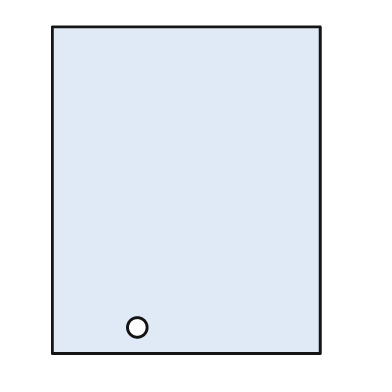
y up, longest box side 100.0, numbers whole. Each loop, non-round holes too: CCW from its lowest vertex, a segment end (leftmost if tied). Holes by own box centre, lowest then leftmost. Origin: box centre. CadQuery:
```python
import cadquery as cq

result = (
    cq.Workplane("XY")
    .moveTo(-41.0, -50.0)
    .lineTo(41.0, -50.0)
    .lineTo(41.0, 50.0)
    .lineTo(-41.0, 50.0)
    .close()
    .moveTo(-15.0, -42.0)
    .circle(3.0)
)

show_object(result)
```